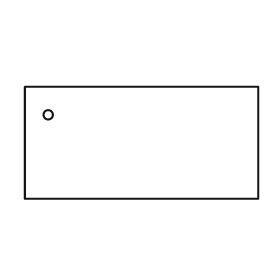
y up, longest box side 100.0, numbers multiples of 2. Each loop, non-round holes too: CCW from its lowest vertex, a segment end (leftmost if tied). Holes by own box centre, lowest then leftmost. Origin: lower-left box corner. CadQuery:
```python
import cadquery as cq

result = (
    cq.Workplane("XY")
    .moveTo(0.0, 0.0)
    .lineTo(100.0, 0.0)
    .lineTo(100.0, 48.0)
    .lineTo(0.0, 48.0)
    .close()
    .moveTo(10.0, 36.0)
    .circle(2.0)
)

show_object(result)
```